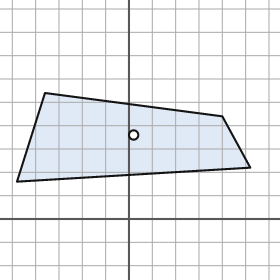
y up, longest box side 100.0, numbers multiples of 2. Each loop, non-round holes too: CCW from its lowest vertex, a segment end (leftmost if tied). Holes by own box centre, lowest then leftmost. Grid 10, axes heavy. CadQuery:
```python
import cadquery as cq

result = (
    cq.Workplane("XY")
    .moveTo(-48.0, 16.0)
    .lineTo(52.0, 22.0)
    .lineTo(40.0, 44.0)
    .lineTo(-36.0, 54.0)
    .close()
    .moveTo(2.0, 36.0)
    .circle(2.0)
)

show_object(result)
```